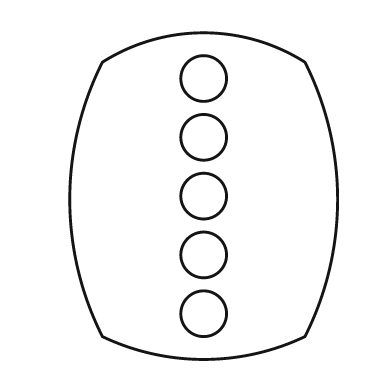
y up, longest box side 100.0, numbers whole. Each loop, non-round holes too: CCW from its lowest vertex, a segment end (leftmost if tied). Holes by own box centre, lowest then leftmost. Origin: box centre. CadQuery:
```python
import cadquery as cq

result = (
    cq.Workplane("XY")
    .moveTo(-31.0, -43.0)
    .threePointArc((0.0, -50.0), (31.0, -43.0))
    .threePointArc((41.0, -1.0), (31.0, 41.0))
    .threePointArc((0.0, 50.0), (-31.0, 41.0))
    .threePointArc((-41.0, -1.0), (-31.0, -43.0))
    .close()
    .moveTo(0.0, -36.0)
    .circle(7.0)
    .moveTo(0.0, -18.0)
    .circle(7.0)
    .moveTo(0.0, 0.0)
    .circle(7.0)
    .moveTo(0.0, 18.0)
    .circle(7.0)
    .moveTo(0.0, 36.0)
    .circle(7.0)
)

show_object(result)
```